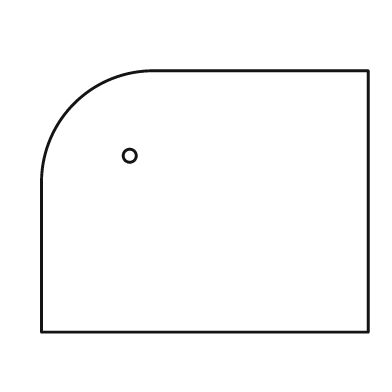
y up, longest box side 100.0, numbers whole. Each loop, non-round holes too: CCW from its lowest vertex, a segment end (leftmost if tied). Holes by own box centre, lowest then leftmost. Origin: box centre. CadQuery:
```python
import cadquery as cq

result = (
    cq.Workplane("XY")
    .moveTo(-50.0, -40.0)
    .lineTo(50.0, -40.0)
    .lineTo(50.0, 40.0)
    .lineTo(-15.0, 40.0)
    .threePointArc((-40.0, 30.0), (-50.0, 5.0))
    .close()
    .moveTo(-23.0, 14.0)
    .circle(2.0)
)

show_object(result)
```